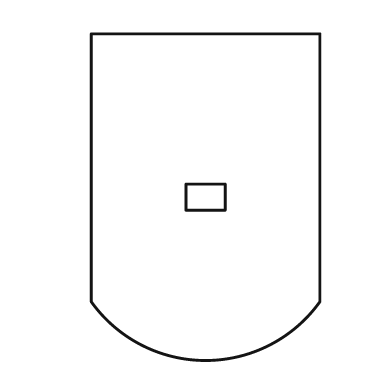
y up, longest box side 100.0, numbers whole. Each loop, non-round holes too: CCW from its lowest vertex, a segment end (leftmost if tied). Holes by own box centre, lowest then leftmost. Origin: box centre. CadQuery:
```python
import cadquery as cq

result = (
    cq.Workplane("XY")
    .moveTo(-35.0, -32.0)
    .threePointArc((0.0, -50.0), (35.0, -32.0))
    .lineTo(35.0, 50.0)
    .lineTo(-35.0, 50.0)
    .close()
    .moveTo(-6.0, -4.0)
    .lineTo(6.0, -4.0)
    .lineTo(6.0, 4.0)
    .lineTo(-6.0, 4.0)
    .close()
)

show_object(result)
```